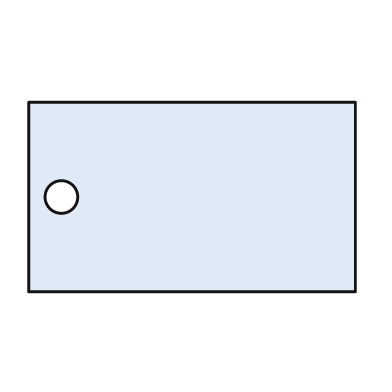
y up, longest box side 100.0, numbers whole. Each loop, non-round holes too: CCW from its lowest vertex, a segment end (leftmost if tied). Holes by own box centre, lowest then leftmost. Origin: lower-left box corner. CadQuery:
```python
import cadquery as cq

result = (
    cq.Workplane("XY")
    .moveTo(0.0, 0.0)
    .lineTo(100.0, 0.0)
    .lineTo(100.0, 58.0)
    .lineTo(0.0, 58.0)
    .close()
    .moveTo(10.0, 29.0)
    .circle(5.0)
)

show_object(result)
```